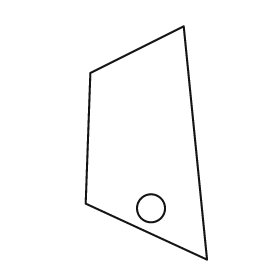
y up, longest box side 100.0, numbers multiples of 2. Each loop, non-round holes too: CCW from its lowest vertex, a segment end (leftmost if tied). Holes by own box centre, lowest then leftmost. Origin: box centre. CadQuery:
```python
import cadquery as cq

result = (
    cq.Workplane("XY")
    .moveTo(26.0, -50.0)
    .lineTo(16.0, 50.0)
    .lineTo(-24.0, 30.0)
    .lineTo(-26.0, -26.0)
    .close()
    .moveTo(2.0, -28.0)
    .circle(6.0)
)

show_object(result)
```